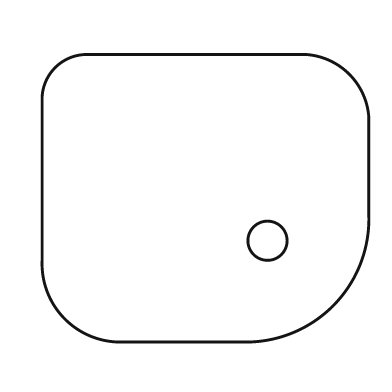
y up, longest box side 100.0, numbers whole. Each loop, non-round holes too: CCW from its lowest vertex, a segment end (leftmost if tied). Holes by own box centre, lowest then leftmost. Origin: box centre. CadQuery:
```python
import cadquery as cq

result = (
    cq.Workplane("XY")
    .moveTo(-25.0, -44.0)
    .lineTo(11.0, -44.0)
    .threePointArc((39.0, -33.0), (50.0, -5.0))
    .lineTo(50.0, 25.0)
    .threePointArc((44.0, 38.0), (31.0, 44.0))
    .lineTo(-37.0, 44.0)
    .threePointArc((-46.0, 40.0), (-50.0, 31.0))
    .lineTo(-50.0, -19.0)
    .threePointArc((-43.0, -37.0), (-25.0, -44.0))
    .close()
    .moveTo(19.0, -13.0)
    .circle(6.0)
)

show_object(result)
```